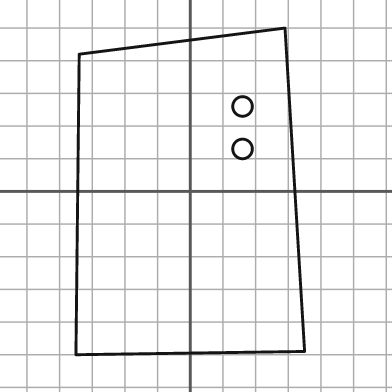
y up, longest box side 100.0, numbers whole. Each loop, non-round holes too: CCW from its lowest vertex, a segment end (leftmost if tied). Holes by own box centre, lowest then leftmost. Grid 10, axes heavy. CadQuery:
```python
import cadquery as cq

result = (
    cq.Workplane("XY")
    .moveTo(-35.0, -50.0)
    .lineTo(35.0, -49.0)
    .lineTo(29.0, 50.0)
    .lineTo(-34.0, 42.0)
    .close()
    .moveTo(16.0, 13.0)
    .circle(3.0)
    .moveTo(16.0, 26.0)
    .circle(3.0)
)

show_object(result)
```